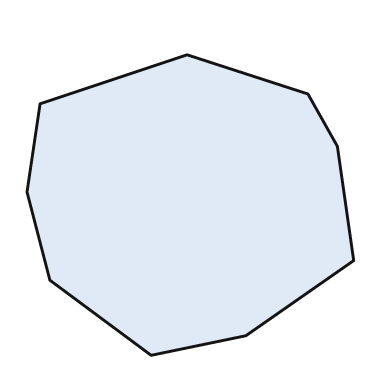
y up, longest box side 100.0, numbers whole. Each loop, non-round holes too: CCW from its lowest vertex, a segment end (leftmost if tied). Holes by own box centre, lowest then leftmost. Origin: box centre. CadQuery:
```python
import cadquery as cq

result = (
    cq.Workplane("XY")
    .moveTo(-12.0, -46.0)
    .lineTo(17.0, -40.0)
    .lineTo(50.0, -17.0)
    .lineTo(45.0, 18.0)
    .lineTo(36.0, 34.0)
    .lineTo(-1.0, 46.0)
    .lineTo(-46.0, 31.0)
    .lineTo(-50.0, 4.0)
    .lineTo(-43.0, -23.0)
    .close()
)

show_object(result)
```